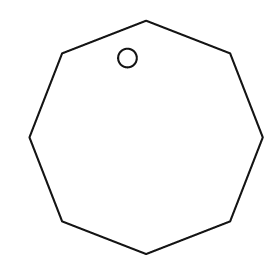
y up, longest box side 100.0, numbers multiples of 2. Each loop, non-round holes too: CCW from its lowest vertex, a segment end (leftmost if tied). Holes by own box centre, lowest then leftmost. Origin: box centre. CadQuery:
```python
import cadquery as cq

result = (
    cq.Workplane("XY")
    .moveTo(0.0, -50.0)
    .lineTo(36.0, -36.0)
    .lineTo(50.0, 0.0)
    .lineTo(36.0, 36.0)
    .lineTo(0.0, 50.0)
    .lineTo(-36.0, 36.0)
    .lineTo(-50.0, 0.0)
    .lineTo(-36.0, -36.0)
    .close()
    .moveTo(-8.0, 34.0)
    .circle(4.0)
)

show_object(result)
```